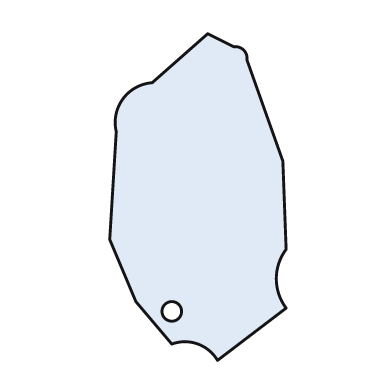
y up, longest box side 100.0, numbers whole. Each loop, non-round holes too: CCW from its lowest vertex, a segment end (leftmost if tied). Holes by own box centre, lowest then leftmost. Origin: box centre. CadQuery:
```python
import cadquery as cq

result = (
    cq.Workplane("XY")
    .moveTo(6.0, -50.0)
    .lineTo(27.0, -34.0)
    .threePointArc((24.0, -25.0), (27.0, -16.0))
    .lineTo(26.0, 11.0)
    .lineTo(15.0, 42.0)
    .threePointArc((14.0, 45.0), (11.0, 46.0))
    .lineTo(3.0, 50.0)
    .lineTo(-14.0, 35.0)
    .threePointArc((-23.0, 30.0), (-25.0, 20.0))
    .lineTo(-27.0, -13.0)
    .lineTo(-19.0, -32.0)
    .lineTo(-8.0, -45.0)
    .threePointArc((0.0, -45.0), (6.0, -50.0))
    .close()
    .moveTo(-8.0, -35.0)
    .circle(3.0)
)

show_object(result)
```